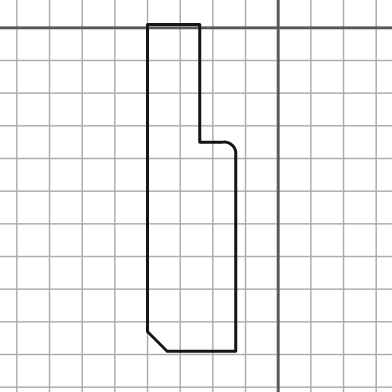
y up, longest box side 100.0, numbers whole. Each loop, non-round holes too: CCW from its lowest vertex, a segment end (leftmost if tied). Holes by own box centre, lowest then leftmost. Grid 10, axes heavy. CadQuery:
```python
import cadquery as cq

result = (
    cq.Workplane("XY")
    .moveTo(-34.0, -99.0)
    .lineTo(-13.0, -99.0)
    .lineTo(-13.0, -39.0)
    .threePointArc((-14.0, -36.0), (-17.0, -35.0))
    .lineTo(-24.0, -35.0)
    .lineTo(-24.0, 1.0)
    .lineTo(-40.0, 1.0)
    .lineTo(-40.0, -93.0)
    .close()
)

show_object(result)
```